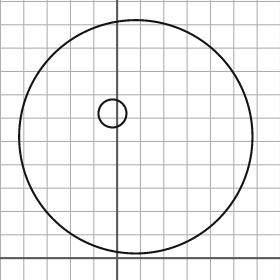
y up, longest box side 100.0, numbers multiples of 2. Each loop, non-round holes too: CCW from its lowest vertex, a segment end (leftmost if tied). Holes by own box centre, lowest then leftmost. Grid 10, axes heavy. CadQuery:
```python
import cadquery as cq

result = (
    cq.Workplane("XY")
    .moveTo(8.0, 52.0)
    .circle(50.0)
    .moveTo(-2.0, 62.0)
    .circle(6.0)
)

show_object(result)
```